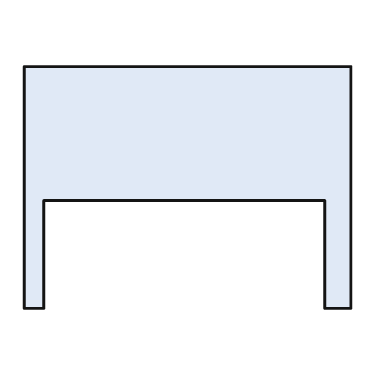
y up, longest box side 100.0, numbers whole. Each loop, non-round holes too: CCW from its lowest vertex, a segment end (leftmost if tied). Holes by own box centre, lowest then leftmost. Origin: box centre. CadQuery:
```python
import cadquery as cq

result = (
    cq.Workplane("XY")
    .moveTo(-50.0, -37.0)
    .lineTo(-44.0, -37.0)
    .lineTo(-44.0, -4.0)
    .lineTo(42.0, -4.0)
    .lineTo(42.0, -37.0)
    .lineTo(50.0, -37.0)
    .lineTo(50.0, 37.0)
    .lineTo(-50.0, 37.0)
    .close()
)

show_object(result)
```